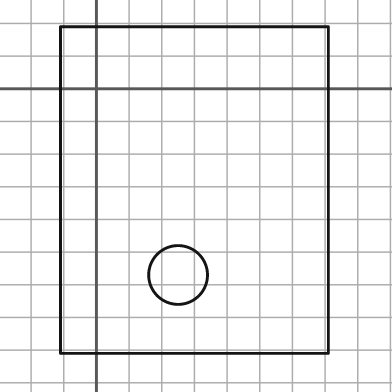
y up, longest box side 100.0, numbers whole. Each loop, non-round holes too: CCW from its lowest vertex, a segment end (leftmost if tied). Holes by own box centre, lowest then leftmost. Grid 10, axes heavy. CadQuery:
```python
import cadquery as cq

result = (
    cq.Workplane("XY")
    .moveTo(-11.0, -81.0)
    .lineTo(71.0, -81.0)
    .lineTo(71.0, 19.0)
    .lineTo(-11.0, 19.0)
    .close()
    .moveTo(25.0, -57.0)
    .circle(9.0)
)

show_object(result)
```